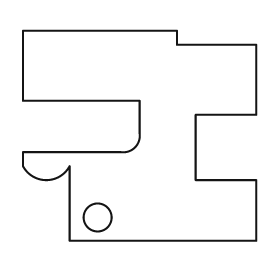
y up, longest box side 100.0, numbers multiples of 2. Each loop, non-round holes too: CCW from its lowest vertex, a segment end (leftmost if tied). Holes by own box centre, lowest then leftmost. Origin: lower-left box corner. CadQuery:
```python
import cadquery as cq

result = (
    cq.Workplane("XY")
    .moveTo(20.0, 0.0)
    .lineTo(100.0, 0.0)
    .lineTo(100.0, 26.0)
    .lineTo(74.0, 26.0)
    .lineTo(74.0, 54.0)
    .lineTo(100.0, 54.0)
    .lineTo(100.0, 84.0)
    .lineTo(66.0, 84.0)
    .lineTo(66.0, 90.0)
    .lineTo(0.0, 90.0)
    .lineTo(0.0, 60.0)
    .lineTo(50.0, 60.0)
    .lineTo(50.0, 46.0)
    .threePointArc((48.0, 40.0), (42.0, 38.0))
    .lineTo(0.0, 38.0)
    .lineTo(0.0, 32.0)
    .threePointArc((10.0, 26.0), (20.0, 32.0))
    .close()
    .moveTo(32.0, 10.0)
    .circle(6.0)
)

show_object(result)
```